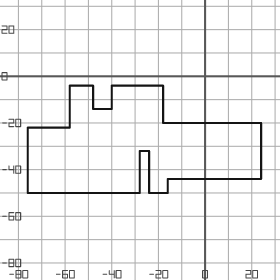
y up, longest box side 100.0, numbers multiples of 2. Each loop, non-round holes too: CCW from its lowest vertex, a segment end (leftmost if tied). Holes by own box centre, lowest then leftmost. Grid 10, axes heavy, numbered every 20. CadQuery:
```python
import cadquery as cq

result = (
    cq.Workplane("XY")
    .moveTo(-76.0, -50.0)
    .lineTo(-28.0, -50.0)
    .lineTo(-28.0, -32.0)
    .lineTo(-24.0, -32.0)
    .lineTo(-24.0, -50.0)
    .lineTo(-16.0, -50.0)
    .lineTo(-16.0, -44.0)
    .lineTo(24.0, -44.0)
    .lineTo(24.0, -20.0)
    .lineTo(-18.0, -20.0)
    .lineTo(-18.0, -4.0)
    .lineTo(-40.0, -4.0)
    .lineTo(-40.0, -14.0)
    .lineTo(-48.0, -14.0)
    .lineTo(-48.0, -4.0)
    .lineTo(-58.0, -4.0)
    .lineTo(-58.0, -22.0)
    .lineTo(-76.0, -22.0)
    .close()
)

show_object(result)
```